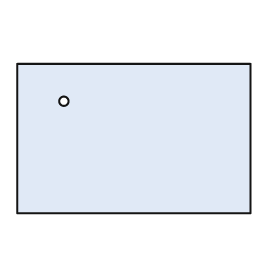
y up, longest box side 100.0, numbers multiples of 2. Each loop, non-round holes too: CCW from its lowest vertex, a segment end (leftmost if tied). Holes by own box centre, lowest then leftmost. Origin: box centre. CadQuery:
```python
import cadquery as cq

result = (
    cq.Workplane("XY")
    .moveTo(-50.0, -32.0)
    .lineTo(50.0, -32.0)
    .lineTo(50.0, 32.0)
    .lineTo(-50.0, 32.0)
    .close()
    .moveTo(-30.0, 16.0)
    .circle(2.0)
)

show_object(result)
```